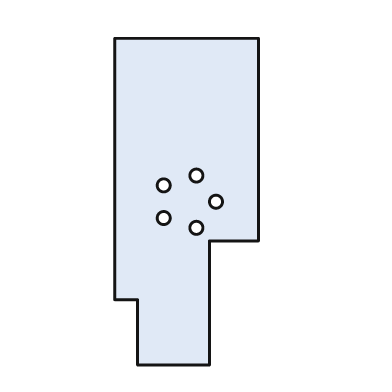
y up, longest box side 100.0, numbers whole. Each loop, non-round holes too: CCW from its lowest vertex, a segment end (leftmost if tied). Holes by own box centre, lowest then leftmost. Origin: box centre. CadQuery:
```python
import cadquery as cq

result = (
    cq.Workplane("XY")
    .moveTo(-15.0, -50.0)
    .lineTo(7.0, -50.0)
    .lineTo(7.0, -12.0)
    .lineTo(22.0, -12.0)
    .lineTo(22.0, 50.0)
    .lineTo(-22.0, 50.0)
    .lineTo(-22.0, -30.0)
    .lineTo(-15.0, -30.0)
    .close()
    .moveTo(3.0, -8.0)
    .circle(2.0)
    .moveTo(-7.0, -5.0)
    .circle(2.0)
    .moveTo(9.0, 0.0)
    .circle(2.0)
    .moveTo(-7.0, 5.0)
    .circle(2.0)
    .moveTo(3.0, 8.0)
    .circle(2.0)
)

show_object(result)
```